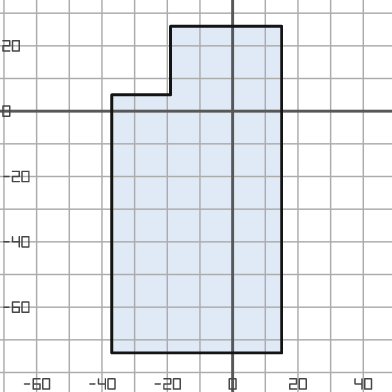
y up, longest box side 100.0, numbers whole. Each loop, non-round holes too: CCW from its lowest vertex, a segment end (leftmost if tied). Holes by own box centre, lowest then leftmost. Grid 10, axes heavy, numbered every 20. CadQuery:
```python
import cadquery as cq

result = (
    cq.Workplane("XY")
    .moveTo(-37.0, -74.0)
    .lineTo(15.0, -74.0)
    .lineTo(15.0, 26.0)
    .lineTo(-19.0, 26.0)
    .lineTo(-19.0, 5.0)
    .lineTo(-37.0, 5.0)
    .close()
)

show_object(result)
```